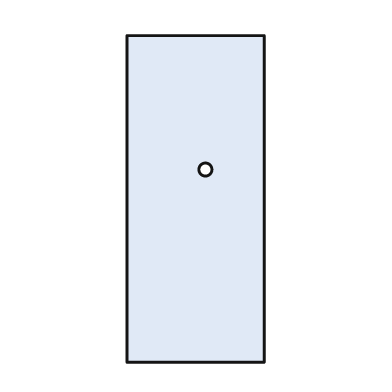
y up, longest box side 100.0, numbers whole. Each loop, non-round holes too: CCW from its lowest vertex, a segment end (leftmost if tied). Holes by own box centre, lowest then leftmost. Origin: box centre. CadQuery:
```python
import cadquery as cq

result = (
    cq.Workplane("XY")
    .moveTo(-21.0, -50.0)
    .lineTo(21.0, -50.0)
    .lineTo(21.0, 50.0)
    .lineTo(-21.0, 50.0)
    .close()
    .moveTo(3.0, 9.0)
    .circle(2.0)
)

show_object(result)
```